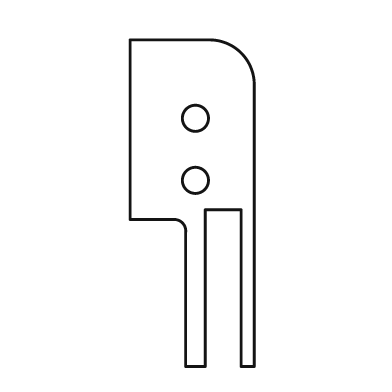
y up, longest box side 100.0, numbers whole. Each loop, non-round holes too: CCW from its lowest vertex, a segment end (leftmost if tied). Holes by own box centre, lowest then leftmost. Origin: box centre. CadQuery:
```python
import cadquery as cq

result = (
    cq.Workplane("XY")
    .moveTo(-2.0, -50.0)
    .lineTo(4.0, -50.0)
    .lineTo(4.0, -2.0)
    .lineTo(15.0, -2.0)
    .lineTo(15.0, -50.0)
    .lineTo(19.0, -50.0)
    .lineTo(19.0, 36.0)
    .threePointArc((15.0, 46.0), (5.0, 50.0))
    .lineTo(-19.0, 50.0)
    .lineTo(-19.0, -5.0)
    .lineTo(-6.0, -5.0)
    .threePointArc((-3.0, -6.0), (-2.0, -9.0))
    .close()
    .moveTo(1.0, 7.0)
    .circle(4.0)
    .moveTo(1.0, 26.0)
    .circle(4.0)
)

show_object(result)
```